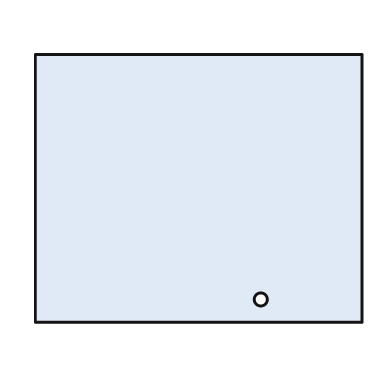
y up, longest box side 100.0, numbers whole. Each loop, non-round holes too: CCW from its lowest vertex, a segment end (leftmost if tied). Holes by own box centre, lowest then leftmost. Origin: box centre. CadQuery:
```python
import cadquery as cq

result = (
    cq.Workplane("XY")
    .moveTo(-50.0, -41.0)
    .lineTo(50.0, -41.0)
    .lineTo(50.0, 41.0)
    .lineTo(-50.0, 41.0)
    .close()
    .moveTo(19.0, -34.0)
    .circle(2.0)
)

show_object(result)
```